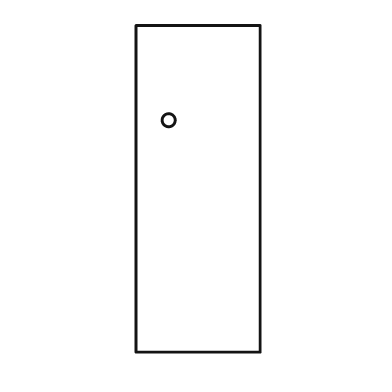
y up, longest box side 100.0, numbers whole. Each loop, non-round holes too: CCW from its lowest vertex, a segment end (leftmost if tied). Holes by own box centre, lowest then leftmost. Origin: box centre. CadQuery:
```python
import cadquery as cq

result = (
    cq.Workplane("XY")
    .moveTo(-19.0, -50.0)
    .lineTo(19.0, -50.0)
    .lineTo(19.0, 50.0)
    .lineTo(-19.0, 50.0)
    .close()
    .moveTo(-9.0, 21.0)
    .circle(2.0)
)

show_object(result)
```